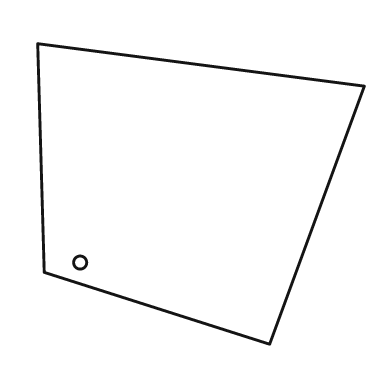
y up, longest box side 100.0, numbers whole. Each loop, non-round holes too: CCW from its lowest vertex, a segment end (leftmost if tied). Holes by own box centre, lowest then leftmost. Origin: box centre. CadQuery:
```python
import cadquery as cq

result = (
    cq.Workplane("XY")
    .moveTo(21.0, -46.0)
    .lineTo(50.0, 33.0)
    .lineTo(-50.0, 46.0)
    .lineTo(-48.0, -24.0)
    .close()
    .moveTo(-37.0, -21.0)
    .circle(2.0)
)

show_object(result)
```